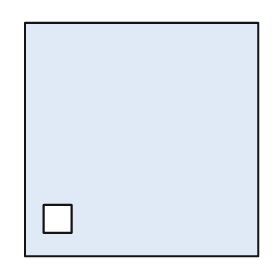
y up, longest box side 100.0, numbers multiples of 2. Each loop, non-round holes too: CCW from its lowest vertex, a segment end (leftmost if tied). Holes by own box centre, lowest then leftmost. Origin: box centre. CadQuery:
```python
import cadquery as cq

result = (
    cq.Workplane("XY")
    .moveTo(-50.0, -50.0)
    .lineTo(50.0, -50.0)
    .lineTo(50.0, 50.0)
    .lineTo(-50.0, 50.0)
    .close()
    .moveTo(-42.0, -40.0)
    .lineTo(-30.0, -40.0)
    .lineTo(-30.0, -28.0)
    .lineTo(-42.0, -28.0)
    .close()
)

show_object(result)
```